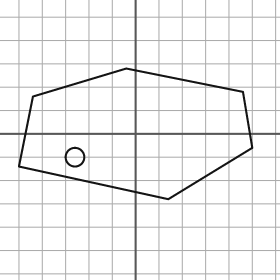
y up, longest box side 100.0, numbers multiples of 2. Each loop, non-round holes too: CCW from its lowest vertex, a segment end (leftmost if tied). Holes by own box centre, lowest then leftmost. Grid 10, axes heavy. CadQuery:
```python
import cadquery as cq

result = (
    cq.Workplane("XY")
    .moveTo(14.0, -28.0)
    .lineTo(50.0, -6.0)
    .lineTo(46.0, 18.0)
    .lineTo(-4.0, 28.0)
    .lineTo(-44.0, 16.0)
    .lineTo(-50.0, -14.0)
    .close()
    .moveTo(-26.0, -10.0)
    .circle(4.0)
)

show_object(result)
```